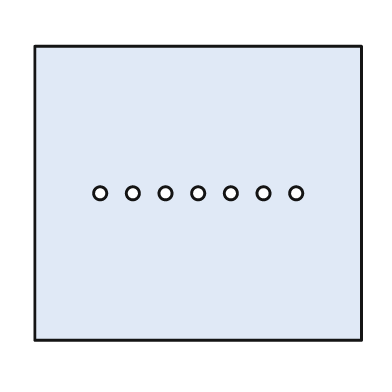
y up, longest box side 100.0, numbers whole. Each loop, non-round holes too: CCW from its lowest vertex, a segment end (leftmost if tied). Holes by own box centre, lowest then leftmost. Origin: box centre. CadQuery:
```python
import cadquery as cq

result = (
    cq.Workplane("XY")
    .moveTo(-50.0, -45.0)
    .lineTo(50.0, -45.0)
    .lineTo(50.0, 45.0)
    .lineTo(-50.0, 45.0)
    .close()
    .moveTo(-30.0, 0.0)
    .circle(2.0)
    .moveTo(-20.0, 0.0)
    .circle(2.0)
    .moveTo(-10.0, 0.0)
    .circle(2.0)
    .moveTo(0.0, 0.0)
    .circle(2.0)
    .moveTo(10.0, 0.0)
    .circle(2.0)
    .moveTo(20.0, 0.0)
    .circle(2.0)
    .moveTo(30.0, 0.0)
    .circle(2.0)
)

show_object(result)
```